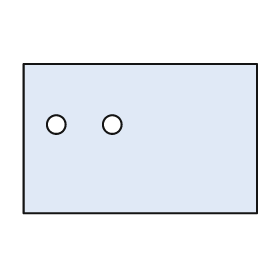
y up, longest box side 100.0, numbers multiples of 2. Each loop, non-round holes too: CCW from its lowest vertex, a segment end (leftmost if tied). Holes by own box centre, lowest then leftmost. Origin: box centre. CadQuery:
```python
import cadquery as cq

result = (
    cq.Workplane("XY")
    .moveTo(-50.0, -32.0)
    .lineTo(50.0, -32.0)
    .lineTo(50.0, 32.0)
    .lineTo(-50.0, 32.0)
    .close()
    .moveTo(-36.0, 6.0)
    .circle(4.0)
    .moveTo(-12.0, 6.0)
    .circle(4.0)
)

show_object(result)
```